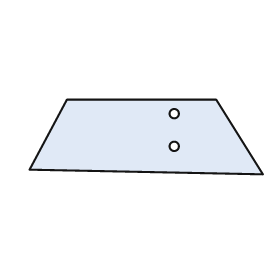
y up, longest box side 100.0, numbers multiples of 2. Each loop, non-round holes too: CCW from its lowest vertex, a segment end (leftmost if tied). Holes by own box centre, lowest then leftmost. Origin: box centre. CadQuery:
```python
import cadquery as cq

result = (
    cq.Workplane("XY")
    .moveTo(50.0, -16.0)
    .lineTo(30.0, 16.0)
    .lineTo(-34.0, 16.0)
    .lineTo(-50.0, -14.0)
    .close()
    .moveTo(12.0, -4.0)
    .circle(2.0)
    .moveTo(12.0, 10.0)
    .circle(2.0)
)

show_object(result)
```